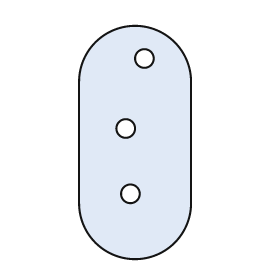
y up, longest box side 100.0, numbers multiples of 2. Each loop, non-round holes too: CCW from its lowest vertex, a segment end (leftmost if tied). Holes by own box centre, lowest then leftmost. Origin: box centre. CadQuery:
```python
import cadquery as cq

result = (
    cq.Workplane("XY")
    .moveTo(-24.0, -26.0)
    .threePointArc((0.0, -50.0), (24.0, -26.0))
    .lineTo(24.0, 26.0)
    .threePointArc((0.0, 50.0), (-24.0, 26.0))
    .close()
    .moveTo(-2.0, -22.0)
    .circle(4.0)
    .moveTo(-4.0, 6.0)
    .circle(4.0)
    .moveTo(4.0, 36.0)
    .circle(4.0)
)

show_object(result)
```